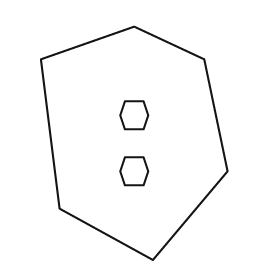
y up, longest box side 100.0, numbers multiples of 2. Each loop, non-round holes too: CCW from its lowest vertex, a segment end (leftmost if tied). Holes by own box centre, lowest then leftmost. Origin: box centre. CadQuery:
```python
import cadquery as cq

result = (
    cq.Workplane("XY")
    .moveTo(8.0, -50.0)
    .lineTo(40.0, -12.0)
    .lineTo(30.0, 36.0)
    .lineTo(0.0, 50.0)
    .lineTo(-40.0, 36.0)
    .lineTo(-32.0, -28.0)
    .close()
    .moveTo(-4.0, -18.0)
    .lineTo(4.0, -18.0)
    .lineTo(6.0, -12.0)
    .lineTo(4.0, -6.0)
    .lineTo(-4.0, -6.0)
    .lineTo(-6.0, -12.0)
    .close()
    .moveTo(-4.0, 6.0)
    .lineTo(4.0, 6.0)
    .lineTo(6.0, 12.0)
    .lineTo(4.0, 18.0)
    .lineTo(-4.0, 18.0)
    .lineTo(-6.0, 12.0)
    .close()
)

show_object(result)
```